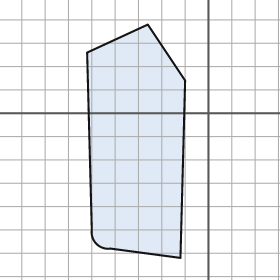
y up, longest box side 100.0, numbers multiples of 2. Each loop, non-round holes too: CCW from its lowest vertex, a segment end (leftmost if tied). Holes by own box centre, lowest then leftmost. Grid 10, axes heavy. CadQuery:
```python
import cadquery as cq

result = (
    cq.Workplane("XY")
    .moveTo(-12.0, -62.0)
    .lineTo(-10.0, 14.0)
    .lineTo(-26.0, 38.0)
    .lineTo(-52.0, 26.0)
    .lineTo(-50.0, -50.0)
    .threePointArc((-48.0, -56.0), (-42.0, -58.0))
    .close()
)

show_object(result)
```